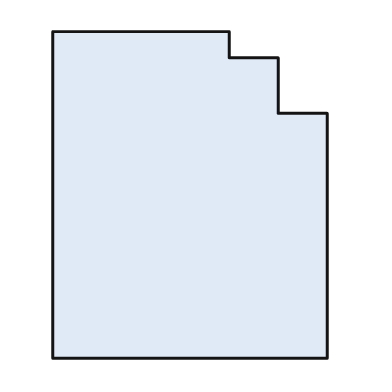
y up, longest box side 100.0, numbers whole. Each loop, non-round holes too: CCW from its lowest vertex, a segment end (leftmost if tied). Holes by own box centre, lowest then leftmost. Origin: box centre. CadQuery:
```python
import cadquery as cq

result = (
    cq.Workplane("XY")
    .moveTo(-42.0, -50.0)
    .lineTo(42.0, -50.0)
    .lineTo(42.0, 25.0)
    .lineTo(27.0, 25.0)
    .lineTo(27.0, 42.0)
    .lineTo(12.0, 42.0)
    .lineTo(12.0, 50.0)
    .lineTo(-42.0, 50.0)
    .close()
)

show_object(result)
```